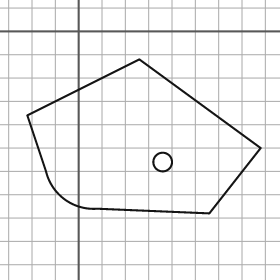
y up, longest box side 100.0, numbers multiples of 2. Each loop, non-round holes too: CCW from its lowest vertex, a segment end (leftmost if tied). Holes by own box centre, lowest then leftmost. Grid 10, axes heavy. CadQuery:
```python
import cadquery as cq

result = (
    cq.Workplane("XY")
    .moveTo(56.0, -78.0)
    .lineTo(78.0, -50.0)
    .lineTo(26.0, -12.0)
    .lineTo(-22.0, -36.0)
    .lineTo(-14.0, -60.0)
    .threePointArc((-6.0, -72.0), (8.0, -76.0))
    .close()
    .moveTo(36.0, -56.0)
    .circle(4.0)
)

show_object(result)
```